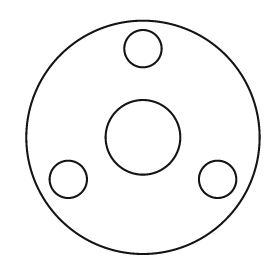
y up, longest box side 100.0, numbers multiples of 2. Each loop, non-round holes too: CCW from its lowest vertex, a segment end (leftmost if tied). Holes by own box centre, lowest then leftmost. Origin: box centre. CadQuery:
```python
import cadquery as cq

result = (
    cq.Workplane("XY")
    .moveTo(0.0, 0.0)
    .circle(50.0)
    .moveTo(-32.0, -18.0)
    .circle(8.0)
    .moveTo(32.0, -18.0)
    .circle(8.0)
    .moveTo(0.0, 0.0)
    .circle(16.0)
    .moveTo(0.0, 38.0)
    .circle(8.0)
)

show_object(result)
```